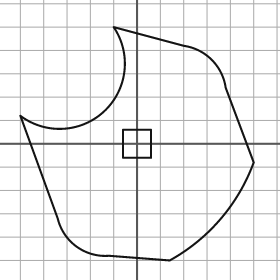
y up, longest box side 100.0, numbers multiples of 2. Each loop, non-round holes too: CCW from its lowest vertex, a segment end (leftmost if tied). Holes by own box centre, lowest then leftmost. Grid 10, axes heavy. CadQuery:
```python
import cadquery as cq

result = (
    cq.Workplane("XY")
    .moveTo(14.0, -50.0)
    .threePointArc((36.0, -32.0), (50.0, -8.0))
    .lineTo(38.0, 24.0)
    .threePointArc((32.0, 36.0), (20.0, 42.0))
    .lineTo(-10.0, 50.0)
    .threePointArc((-14.0, 14.0), (-50.0, 12.0))
    .lineTo(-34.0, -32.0)
    .threePointArc((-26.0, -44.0), (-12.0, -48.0))
    .close()
    .moveTo(-6.0, -6.0)
    .lineTo(6.0, -6.0)
    .lineTo(6.0, 6.0)
    .lineTo(-6.0, 6.0)
    .close()
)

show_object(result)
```